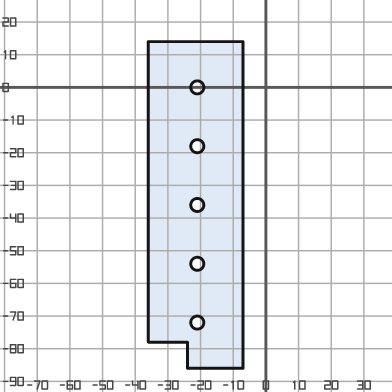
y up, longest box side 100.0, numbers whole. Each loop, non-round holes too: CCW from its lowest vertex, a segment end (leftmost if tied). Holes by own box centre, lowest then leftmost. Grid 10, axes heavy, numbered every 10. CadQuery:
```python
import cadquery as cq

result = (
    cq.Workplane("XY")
    .moveTo(-24.0, -86.0)
    .lineTo(-7.0, -86.0)
    .lineTo(-7.0, 14.0)
    .lineTo(-36.0, 14.0)
    .lineTo(-36.0, -78.0)
    .lineTo(-24.0, -78.0)
    .close()
    .moveTo(-21.0, -72.0)
    .circle(2.0)
    .moveTo(-21.0, -54.0)
    .circle(2.0)
    .moveTo(-21.0, -36.0)
    .circle(2.0)
    .moveTo(-21.0, -18.0)
    .circle(2.0)
    .moveTo(-21.0, 0.0)
    .circle(2.0)
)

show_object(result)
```